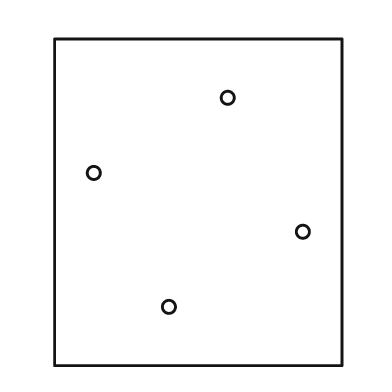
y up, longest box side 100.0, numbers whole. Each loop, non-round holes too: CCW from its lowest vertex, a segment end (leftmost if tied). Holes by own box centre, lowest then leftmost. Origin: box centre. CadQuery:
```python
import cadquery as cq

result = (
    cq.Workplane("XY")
    .moveTo(-44.0, -50.0)
    .lineTo(44.0, -50.0)
    .lineTo(44.0, 50.0)
    .lineTo(-44.0, 50.0)
    .close()
    .moveTo(-9.0, -32.0)
    .circle(2.0)
    .moveTo(32.0, -9.0)
    .circle(2.0)
    .moveTo(-32.0, 9.0)
    .circle(2.0)
    .moveTo(9.0, 32.0)
    .circle(2.0)
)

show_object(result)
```